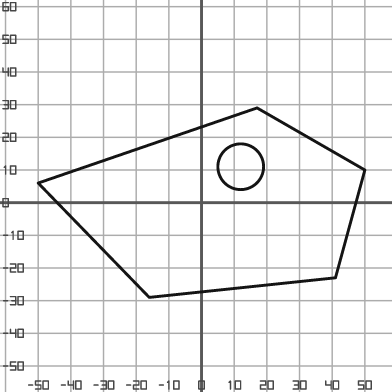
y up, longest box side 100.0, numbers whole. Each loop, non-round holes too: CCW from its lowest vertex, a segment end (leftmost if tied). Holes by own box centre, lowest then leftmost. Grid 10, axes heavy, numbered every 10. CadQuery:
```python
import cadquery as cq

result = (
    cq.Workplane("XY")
    .moveTo(-16.0, -29.0)
    .lineTo(41.0, -23.0)
    .lineTo(50.0, 10.0)
    .lineTo(17.0, 29.0)
    .lineTo(-50.0, 6.0)
    .close()
    .moveTo(12.0, 11.0)
    .circle(7.0)
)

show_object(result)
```